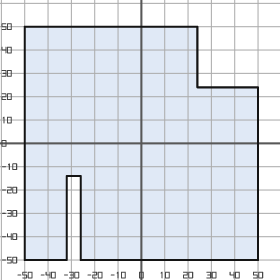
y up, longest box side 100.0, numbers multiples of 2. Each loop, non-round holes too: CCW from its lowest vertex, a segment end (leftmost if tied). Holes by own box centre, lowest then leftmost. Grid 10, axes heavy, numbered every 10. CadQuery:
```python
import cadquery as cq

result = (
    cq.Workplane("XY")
    .moveTo(-50.0, -50.0)
    .lineTo(-32.0, -50.0)
    .lineTo(-32.0, -14.0)
    .lineTo(-26.0, -14.0)
    .lineTo(-26.0, -50.0)
    .lineTo(50.0, -50.0)
    .lineTo(50.0, 24.0)
    .lineTo(24.0, 24.0)
    .lineTo(24.0, 50.0)
    .lineTo(-50.0, 50.0)
    .close()
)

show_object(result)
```